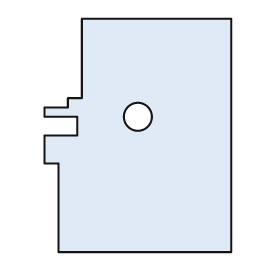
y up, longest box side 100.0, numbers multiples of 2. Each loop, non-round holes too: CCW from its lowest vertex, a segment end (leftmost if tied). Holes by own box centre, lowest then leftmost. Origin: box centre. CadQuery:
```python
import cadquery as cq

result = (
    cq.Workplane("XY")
    .moveTo(-34.0, -50.0)
    .lineTo(40.0, -50.0)
    .lineTo(40.0, 50.0)
    .lineTo(-24.0, 50.0)
    .lineTo(-24.0, 16.0)
    .lineTo(-30.0, 16.0)
    .lineTo(-30.0, 12.0)
    .lineTo(-40.0, 12.0)
    .lineTo(-40.0, 8.0)
    .lineTo(-26.0, 8.0)
    .lineTo(-26.0, 0.0)
    .lineTo(-40.0, 0.0)
    .lineTo(-40.0, -12.0)
    .lineTo(-34.0, -12.0)
    .close()
    .moveTo(0.0, 8.0)
    .circle(6.0)
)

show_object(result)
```